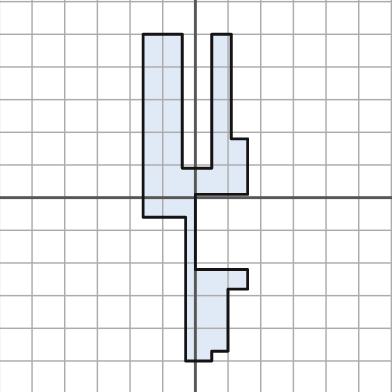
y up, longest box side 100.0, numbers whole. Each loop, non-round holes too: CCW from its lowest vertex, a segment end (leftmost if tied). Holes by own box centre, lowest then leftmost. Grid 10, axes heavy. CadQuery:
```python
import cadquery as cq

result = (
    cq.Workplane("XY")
    .moveTo(-3.0, -50.0)
    .lineTo(5.0, -50.0)
    .lineTo(5.0, -47.0)
    .lineTo(10.0, -47.0)
    .lineTo(10.0, -28.0)
    .lineTo(16.0, -28.0)
    .lineTo(16.0, -22.0)
    .lineTo(0.0, -22.0)
    .lineTo(0.0, 1.0)
    .lineTo(16.0, 1.0)
    .lineTo(16.0, 18.0)
    .lineTo(11.0, 18.0)
    .lineTo(11.0, 50.0)
    .lineTo(5.0, 50.0)
    .lineTo(5.0, 9.0)
    .lineTo(-4.0, 9.0)
    .lineTo(-4.0, 50.0)
    .lineTo(-16.0, 50.0)
    .lineTo(-16.0, -6.0)
    .lineTo(-3.0, -6.0)
    .close()
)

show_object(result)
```